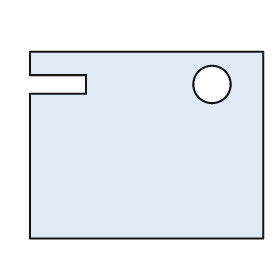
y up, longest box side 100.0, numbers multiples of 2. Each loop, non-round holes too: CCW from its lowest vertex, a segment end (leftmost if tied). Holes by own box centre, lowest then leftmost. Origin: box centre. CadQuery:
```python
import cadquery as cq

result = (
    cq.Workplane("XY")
    .moveTo(-50.0, -40.0)
    .lineTo(50.0, -40.0)
    .lineTo(50.0, 40.0)
    .lineTo(-50.0, 40.0)
    .lineTo(-50.0, 30.0)
    .lineTo(-26.0, 30.0)
    .lineTo(-26.0, 22.0)
    .lineTo(-50.0, 22.0)
    .close()
    .moveTo(28.0, 26.0)
    .circle(8.0)
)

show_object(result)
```